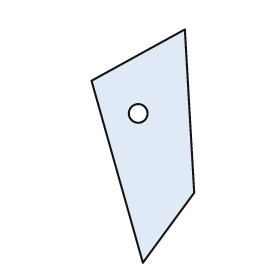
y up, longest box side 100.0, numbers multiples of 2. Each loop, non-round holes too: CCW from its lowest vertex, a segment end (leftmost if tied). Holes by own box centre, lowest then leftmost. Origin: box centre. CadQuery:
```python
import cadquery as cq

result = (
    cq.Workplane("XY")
    .moveTo(0.0, -50.0)
    .lineTo(22.0, -20.0)
    .lineTo(18.0, 50.0)
    .lineTo(-22.0, 28.0)
    .close()
    .moveTo(-2.0, 14.0)
    .circle(4.0)
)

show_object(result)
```